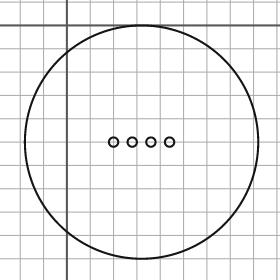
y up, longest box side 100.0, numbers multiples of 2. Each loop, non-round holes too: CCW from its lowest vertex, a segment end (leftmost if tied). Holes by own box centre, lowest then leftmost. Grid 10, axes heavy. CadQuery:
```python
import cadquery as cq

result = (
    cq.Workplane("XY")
    .moveTo(32.0, -50.0)
    .circle(50.0)
    .moveTo(20.0, -50.0)
    .circle(2.0)
    .moveTo(28.0, -50.0)
    .circle(2.0)
    .moveTo(36.0, -50.0)
    .circle(2.0)
    .moveTo(44.0, -50.0)
    .circle(2.0)
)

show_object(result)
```